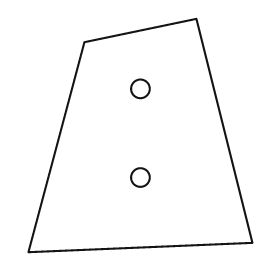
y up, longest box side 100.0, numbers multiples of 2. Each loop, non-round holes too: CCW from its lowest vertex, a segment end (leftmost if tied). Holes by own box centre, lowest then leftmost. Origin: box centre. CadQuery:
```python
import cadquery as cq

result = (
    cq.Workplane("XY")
    .moveTo(-48.0, -50.0)
    .lineTo(48.0, -46.0)
    .lineTo(24.0, 50.0)
    .lineTo(-24.0, 40.0)
    .close()
    .moveTo(0.0, -18.0)
    .circle(4.0)
    .moveTo(0.0, 20.0)
    .circle(4.0)
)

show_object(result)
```